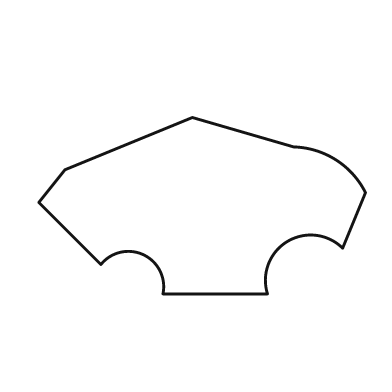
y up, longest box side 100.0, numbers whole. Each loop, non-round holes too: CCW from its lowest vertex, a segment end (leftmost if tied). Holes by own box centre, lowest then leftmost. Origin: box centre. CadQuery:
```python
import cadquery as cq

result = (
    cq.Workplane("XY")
    .moveTo(-12.0, -27.0)
    .lineTo(20.0, -27.0)
    .threePointArc((26.0, -11.0), (43.0, -13.0))
    .lineTo(50.0, 4.0)
    .threePointArc((41.0, 14.0), (28.0, 18.0))
    .lineTo(-3.0, 27.0)
    .lineTo(-42.0, 11.0)
    .lineTo(-50.0, 1.0)
    .lineTo(-31.0, -18.0)
    .threePointArc((-18.0, -15.0), (-12.0, -27.0))
    .close()
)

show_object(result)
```